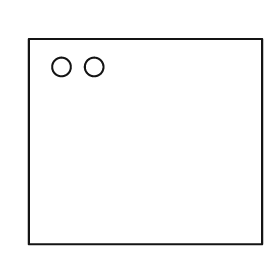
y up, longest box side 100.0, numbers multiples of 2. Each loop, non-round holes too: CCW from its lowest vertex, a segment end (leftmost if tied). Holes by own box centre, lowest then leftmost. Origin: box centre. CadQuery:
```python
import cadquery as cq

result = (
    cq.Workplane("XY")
    .moveTo(-50.0, -44.0)
    .lineTo(50.0, -44.0)
    .lineTo(50.0, 44.0)
    .lineTo(-50.0, 44.0)
    .close()
    .moveTo(-36.0, 32.0)
    .circle(4.0)
    .moveTo(-22.0, 32.0)
    .circle(4.0)
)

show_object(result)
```